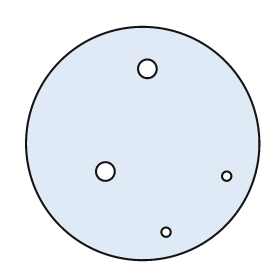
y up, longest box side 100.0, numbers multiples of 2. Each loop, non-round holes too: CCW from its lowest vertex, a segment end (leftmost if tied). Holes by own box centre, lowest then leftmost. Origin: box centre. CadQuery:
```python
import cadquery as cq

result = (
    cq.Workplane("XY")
    .moveTo(0.0, 0.0)
    .circle(50.0)
    .moveTo(10.0, -38.0)
    .circle(2.0)
    .moveTo(36.0, -14.0)
    .circle(2.0)
    .moveTo(-16.0, -12.0)
    .circle(4.0)
    .moveTo(2.0, 32.0)
    .circle(4.0)
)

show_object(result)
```